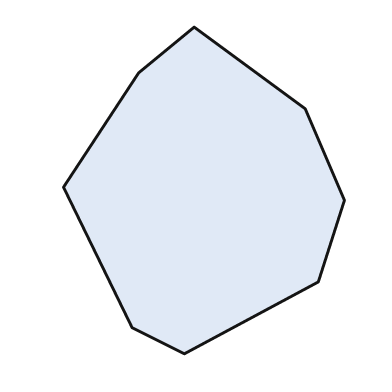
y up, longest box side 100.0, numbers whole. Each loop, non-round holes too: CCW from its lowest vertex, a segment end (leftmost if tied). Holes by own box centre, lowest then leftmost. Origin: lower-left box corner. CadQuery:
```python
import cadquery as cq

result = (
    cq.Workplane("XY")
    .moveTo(37.0, 0.0)
    .lineTo(78.0, 22.0)
    .lineTo(86.0, 47.0)
    .lineTo(74.0, 75.0)
    .lineTo(40.0, 100.0)
    .lineTo(23.0, 86.0)
    .lineTo(0.0, 51.0)
    .lineTo(21.0, 8.0)
    .close()
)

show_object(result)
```